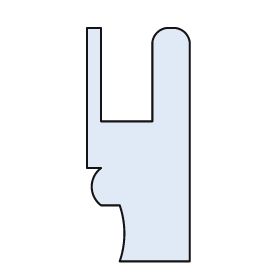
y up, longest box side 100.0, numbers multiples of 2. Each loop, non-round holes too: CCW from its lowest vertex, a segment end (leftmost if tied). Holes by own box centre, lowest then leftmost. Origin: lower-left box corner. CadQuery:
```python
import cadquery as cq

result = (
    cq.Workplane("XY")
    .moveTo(14.0, 0.0)
    .lineTo(44.0, 0.0)
    .lineTo(44.0, 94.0)
    .threePointArc((42.0, 98.0), (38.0, 100.0))
    .lineTo(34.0, 100.0)
    .threePointArc((30.0, 98.0), (28.0, 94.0))
    .lineTo(28.0, 60.0)
    .lineTo(6.0, 60.0)
    .lineTo(6.0, 100.0)
    .lineTo(0.0, 100.0)
    .lineTo(0.0, 40.0)
    .lineTo(6.0, 40.0)
    .threePointArc((2.0, 32.0), (6.0, 24.0))
    .lineTo(14.0, 24.0)
    .threePointArc((16.0, 12.0), (14.0, 0.0))
    .close()
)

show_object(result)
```